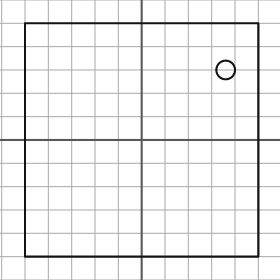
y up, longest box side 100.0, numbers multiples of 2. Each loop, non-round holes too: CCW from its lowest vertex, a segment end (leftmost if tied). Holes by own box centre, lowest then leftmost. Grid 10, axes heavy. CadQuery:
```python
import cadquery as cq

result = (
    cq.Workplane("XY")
    .moveTo(-50.0, -50.0)
    .lineTo(50.0, -50.0)
    .lineTo(50.0, 50.0)
    .lineTo(-50.0, 50.0)
    .close()
    .moveTo(36.0, 30.0)
    .circle(4.0)
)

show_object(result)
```